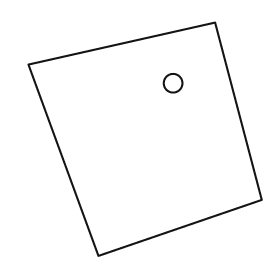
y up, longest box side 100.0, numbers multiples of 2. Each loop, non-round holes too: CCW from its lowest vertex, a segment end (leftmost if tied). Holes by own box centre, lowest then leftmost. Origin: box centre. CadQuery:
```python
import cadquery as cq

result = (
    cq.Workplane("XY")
    .moveTo(-20.0, -50.0)
    .lineTo(50.0, -26.0)
    .lineTo(30.0, 50.0)
    .lineTo(-50.0, 32.0)
    .close()
    .moveTo(12.0, 24.0)
    .circle(4.0)
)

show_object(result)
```